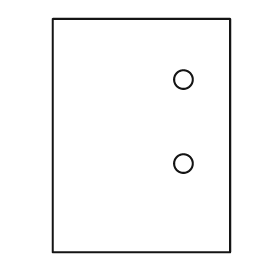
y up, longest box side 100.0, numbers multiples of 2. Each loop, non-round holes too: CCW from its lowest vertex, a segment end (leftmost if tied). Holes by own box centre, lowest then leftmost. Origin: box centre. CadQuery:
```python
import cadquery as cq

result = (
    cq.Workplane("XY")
    .moveTo(-38.0, -50.0)
    .lineTo(38.0, -50.0)
    .lineTo(38.0, 50.0)
    .lineTo(-38.0, 50.0)
    .close()
    .moveTo(18.0, -12.0)
    .circle(4.0)
    .moveTo(18.0, 24.0)
    .circle(4.0)
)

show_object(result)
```